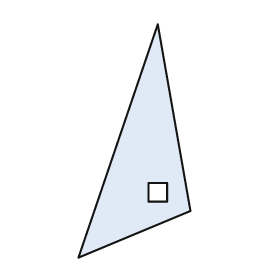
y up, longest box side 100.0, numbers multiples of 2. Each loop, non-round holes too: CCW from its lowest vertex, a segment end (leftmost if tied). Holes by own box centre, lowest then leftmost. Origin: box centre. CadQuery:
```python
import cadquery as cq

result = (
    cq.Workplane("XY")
    .moveTo(-24.0, -50.0)
    .lineTo(24.0, -30.0)
    .lineTo(10.0, 50.0)
    .close()
    .moveTo(6.0, -26.0)
    .lineTo(14.0, -26.0)
    .lineTo(14.0, -18.0)
    .lineTo(6.0, -18.0)
    .close()
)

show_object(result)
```